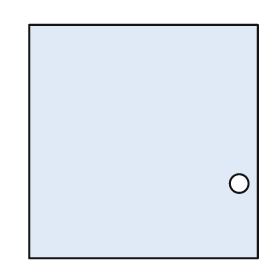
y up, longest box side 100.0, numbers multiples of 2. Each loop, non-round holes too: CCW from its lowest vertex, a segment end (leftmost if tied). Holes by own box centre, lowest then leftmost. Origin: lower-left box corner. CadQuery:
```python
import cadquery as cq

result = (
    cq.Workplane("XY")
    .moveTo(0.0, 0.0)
    .lineTo(98.0, 0.0)
    .lineTo(98.0, 100.0)
    .lineTo(0.0, 100.0)
    .close()
    .moveTo(90.0, 32.0)
    .circle(4.0)
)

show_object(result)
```